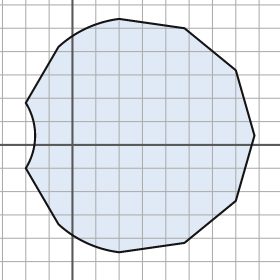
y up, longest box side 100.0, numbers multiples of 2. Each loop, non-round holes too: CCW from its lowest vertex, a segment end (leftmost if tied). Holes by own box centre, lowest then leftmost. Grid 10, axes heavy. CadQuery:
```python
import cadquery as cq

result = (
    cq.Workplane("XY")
    .moveTo(20.0, -46.0)
    .lineTo(48.0, -42.0)
    .lineTo(70.0, -24.0)
    .lineTo(78.0, 4.0)
    .lineTo(70.0, 32.0)
    .lineTo(48.0, 50.0)
    .lineTo(20.0, 54.0)
    .threePointArc((6.0, 50.0), (-6.0, 42.0))
    .lineTo(-20.0, 18.0)
    .threePointArc((-16.0, 4.0), (-20.0, -10.0))
    .lineTo(-6.0, -34.0)
    .threePointArc((6.0, -42.0), (20.0, -46.0))
    .close()
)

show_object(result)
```